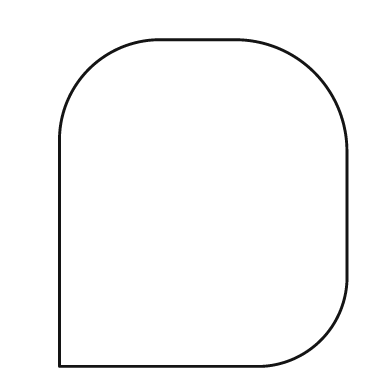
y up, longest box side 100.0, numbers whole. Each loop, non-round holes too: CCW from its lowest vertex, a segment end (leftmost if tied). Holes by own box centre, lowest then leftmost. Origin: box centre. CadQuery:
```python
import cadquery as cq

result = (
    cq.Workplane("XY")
    .moveTo(-44.0, -50.0)
    .lineTo(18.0, -50.0)
    .threePointArc((36.0, -42.0), (44.0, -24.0))
    .lineTo(44.0, 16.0)
    .threePointArc((34.0, 40.0), (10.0, 50.0))
    .lineTo(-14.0, 50.0)
    .threePointArc((-35.0, 41.0), (-44.0, 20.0))
    .close()
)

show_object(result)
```